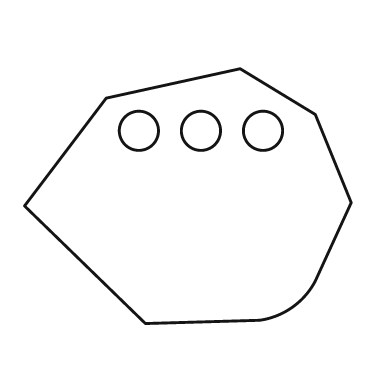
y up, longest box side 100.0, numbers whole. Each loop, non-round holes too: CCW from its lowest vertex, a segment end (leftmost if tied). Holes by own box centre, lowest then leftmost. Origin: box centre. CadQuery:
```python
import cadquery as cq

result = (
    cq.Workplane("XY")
    .moveTo(-13.0, -39.0)
    .lineTo(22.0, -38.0)
    .threePointArc((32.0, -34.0), (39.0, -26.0))
    .lineTo(50.0, -2.0)
    .lineTo(39.0, 25.0)
    .lineTo(16.0, 39.0)
    .lineTo(-25.0, 30.0)
    .lineTo(-50.0, -3.0)
    .close()
    .moveTo(-15.0, 20.0)
    .circle(6.0)
    .moveTo(4.0, 20.0)
    .circle(6.0)
    .moveTo(23.0, 20.0)
    .circle(6.0)
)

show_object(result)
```